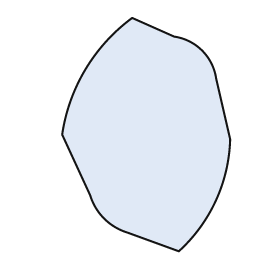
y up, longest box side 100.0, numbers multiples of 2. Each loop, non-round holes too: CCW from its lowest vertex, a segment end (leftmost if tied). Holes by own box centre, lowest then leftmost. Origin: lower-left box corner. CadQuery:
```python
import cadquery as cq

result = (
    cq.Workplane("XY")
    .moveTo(50.0, 0.0)
    .threePointArc((66.0, 22.0), (72.0, 48.0))
    .lineTo(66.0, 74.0)
    .threePointArc((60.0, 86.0), (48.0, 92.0))
    .lineTo(30.0, 100.0)
    .threePointArc((10.0, 78.0), (0.0, 50.0))
    .lineTo(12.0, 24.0)
    .threePointArc((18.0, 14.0), (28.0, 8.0))
    .close()
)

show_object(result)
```